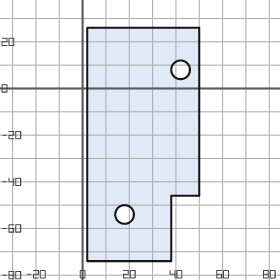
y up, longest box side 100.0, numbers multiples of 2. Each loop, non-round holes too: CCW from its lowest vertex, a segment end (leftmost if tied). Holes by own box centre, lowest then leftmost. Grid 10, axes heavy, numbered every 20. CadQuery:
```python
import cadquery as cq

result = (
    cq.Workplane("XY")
    .moveTo(2.0, -74.0)
    .lineTo(38.0, -74.0)
    .lineTo(38.0, -46.0)
    .lineTo(50.0, -46.0)
    .lineTo(50.0, 26.0)
    .lineTo(2.0, 26.0)
    .close()
    .moveTo(18.0, -54.0)
    .circle(4.0)
    .moveTo(42.0, 8.0)
    .circle(4.0)
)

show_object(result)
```